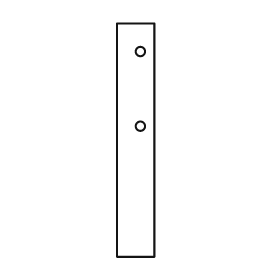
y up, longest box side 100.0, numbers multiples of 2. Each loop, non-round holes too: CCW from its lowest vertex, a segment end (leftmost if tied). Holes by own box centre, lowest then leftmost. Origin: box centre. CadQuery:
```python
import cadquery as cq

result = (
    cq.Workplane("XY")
    .moveTo(-8.0, -50.0)
    .lineTo(8.0, -50.0)
    .lineTo(8.0, 50.0)
    .lineTo(-8.0, 50.0)
    .close()
    .moveTo(2.0, 6.0)
    .circle(2.0)
    .moveTo(2.0, 38.0)
    .circle(2.0)
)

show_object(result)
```